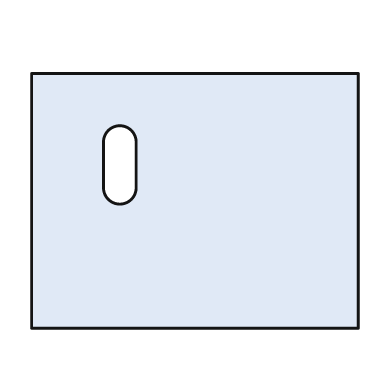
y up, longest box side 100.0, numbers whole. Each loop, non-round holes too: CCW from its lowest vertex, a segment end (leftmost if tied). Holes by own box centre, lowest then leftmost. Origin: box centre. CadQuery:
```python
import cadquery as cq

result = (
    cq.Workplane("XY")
    .moveTo(-50.0, -39.0)
    .lineTo(50.0, -39.0)
    .lineTo(50.0, 39.0)
    .lineTo(-50.0, 39.0)
    .close()
    .moveTo(-28.0, 4.0)
    .threePointArc((-23.0, -1.0), (-18.0, 4.0))
    .lineTo(-18.0, 18.0)
    .threePointArc((-23.0, 23.0), (-28.0, 18.0))
    .close()
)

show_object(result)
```